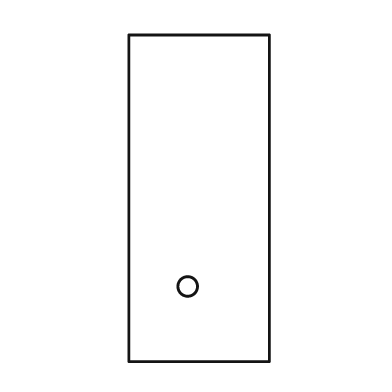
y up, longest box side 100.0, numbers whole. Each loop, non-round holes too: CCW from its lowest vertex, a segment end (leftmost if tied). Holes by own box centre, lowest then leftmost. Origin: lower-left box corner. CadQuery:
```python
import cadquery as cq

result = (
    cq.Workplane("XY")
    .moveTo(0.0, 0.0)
    .lineTo(43.0, 0.0)
    .lineTo(43.0, 100.0)
    .lineTo(0.0, 100.0)
    .close()
    .moveTo(18.0, 23.0)
    .circle(3.0)
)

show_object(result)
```